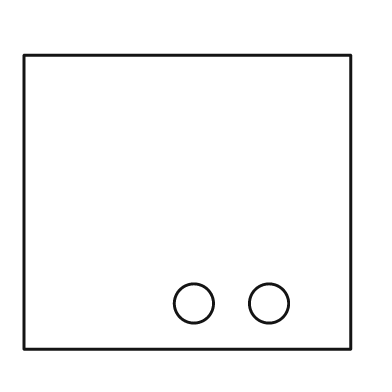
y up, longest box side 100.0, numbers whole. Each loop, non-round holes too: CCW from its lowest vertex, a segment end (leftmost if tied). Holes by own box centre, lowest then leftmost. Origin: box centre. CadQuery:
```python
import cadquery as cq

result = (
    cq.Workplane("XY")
    .moveTo(-50.0, -45.0)
    .lineTo(50.0, -45.0)
    .lineTo(50.0, 45.0)
    .lineTo(-50.0, 45.0)
    .close()
    .moveTo(2.0, -31.0)
    .circle(6.0)
    .moveTo(25.0, -31.0)
    .circle(6.0)
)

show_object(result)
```